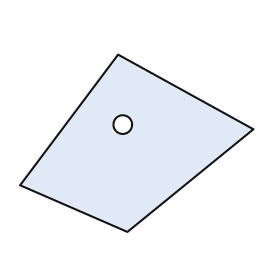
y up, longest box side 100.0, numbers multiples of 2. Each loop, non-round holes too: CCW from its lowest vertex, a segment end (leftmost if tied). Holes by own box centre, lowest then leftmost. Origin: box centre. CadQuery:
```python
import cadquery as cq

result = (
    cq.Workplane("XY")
    .moveTo(-4.0, -38.0)
    .lineTo(50.0, 6.0)
    .lineTo(-8.0, 38.0)
    .lineTo(-50.0, -18.0)
    .close()
    .moveTo(-6.0, 8.0)
    .circle(4.0)
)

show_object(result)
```